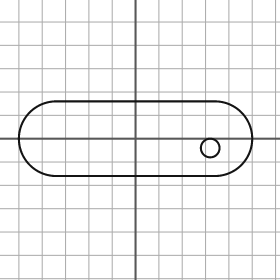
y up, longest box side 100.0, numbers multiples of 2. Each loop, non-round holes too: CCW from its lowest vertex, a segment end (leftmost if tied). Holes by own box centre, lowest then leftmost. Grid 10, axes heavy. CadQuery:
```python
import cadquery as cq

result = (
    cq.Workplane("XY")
    .moveTo(-34.0, -16.0)
    .lineTo(34.0, -16.0)
    .threePointArc((50.0, 0.0), (34.0, 16.0))
    .lineTo(-34.0, 16.0)
    .threePointArc((-50.0, 0.0), (-34.0, -16.0))
    .close()
    .moveTo(32.0, -4.0)
    .circle(4.0)
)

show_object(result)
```